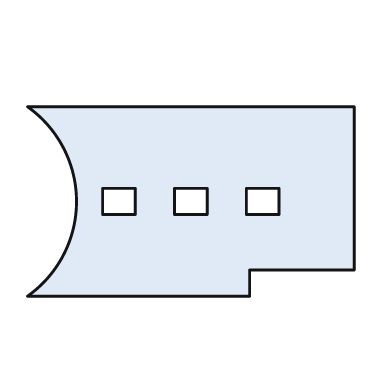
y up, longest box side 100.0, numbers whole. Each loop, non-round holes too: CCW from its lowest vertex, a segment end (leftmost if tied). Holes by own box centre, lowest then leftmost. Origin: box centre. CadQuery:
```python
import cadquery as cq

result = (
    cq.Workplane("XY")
    .moveTo(-50.0, -29.0)
    .lineTo(18.0, -29.0)
    .lineTo(18.0, -21.0)
    .lineTo(50.0, -21.0)
    .lineTo(50.0, 29.0)
    .lineTo(-50.0, 29.0)
    .threePointArc((-35.0, 0.0), (-50.0, -29.0))
    .close()
    .moveTo(-27.0, -4.0)
    .lineTo(-17.0, -4.0)
    .lineTo(-17.0, 4.0)
    .lineTo(-27.0, 4.0)
    .close()
    .moveTo(-5.0, -4.0)
    .lineTo(5.0, -4.0)
    .lineTo(5.0, 4.0)
    .lineTo(-5.0, 4.0)
    .close()
    .moveTo(17.0, -4.0)
    .lineTo(27.0, -4.0)
    .lineTo(27.0, 4.0)
    .lineTo(17.0, 4.0)
    .close()
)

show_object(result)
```